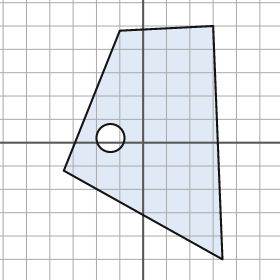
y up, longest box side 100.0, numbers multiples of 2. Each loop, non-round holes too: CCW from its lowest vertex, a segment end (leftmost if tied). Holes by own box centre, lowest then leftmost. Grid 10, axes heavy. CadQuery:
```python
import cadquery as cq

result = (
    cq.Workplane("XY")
    .moveTo(34.0, -50.0)
    .lineTo(30.0, 50.0)
    .lineTo(-10.0, 48.0)
    .lineTo(-34.0, -12.0)
    .close()
    .moveTo(-14.0, 2.0)
    .circle(6.0)
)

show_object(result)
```